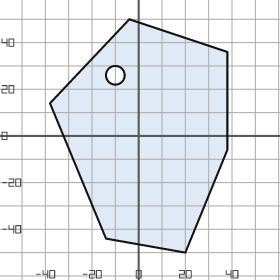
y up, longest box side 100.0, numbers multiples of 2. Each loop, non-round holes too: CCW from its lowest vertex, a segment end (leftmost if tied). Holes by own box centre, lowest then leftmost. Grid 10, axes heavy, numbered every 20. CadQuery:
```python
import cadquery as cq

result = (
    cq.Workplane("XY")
    .moveTo(20.0, -50.0)
    .lineTo(38.0, -6.0)
    .lineTo(38.0, 36.0)
    .lineTo(-4.0, 50.0)
    .lineTo(-38.0, 14.0)
    .lineTo(-14.0, -44.0)
    .close()
    .moveTo(-10.0, 26.0)
    .circle(4.0)
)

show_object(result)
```